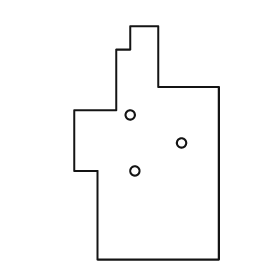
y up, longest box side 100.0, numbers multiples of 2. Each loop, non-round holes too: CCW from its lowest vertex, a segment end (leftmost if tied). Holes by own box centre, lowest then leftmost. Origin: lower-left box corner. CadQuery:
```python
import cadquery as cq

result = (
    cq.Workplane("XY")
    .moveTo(10.0, 0.0)
    .lineTo(62.0, 0.0)
    .lineTo(62.0, 74.0)
    .lineTo(36.0, 74.0)
    .lineTo(36.0, 100.0)
    .lineTo(24.0, 100.0)
    .lineTo(24.0, 90.0)
    .lineTo(18.0, 90.0)
    .lineTo(18.0, 64.0)
    .lineTo(0.0, 64.0)
    .lineTo(0.0, 38.0)
    .lineTo(10.0, 38.0)
    .close()
    .moveTo(26.0, 38.0)
    .circle(2.0)
    .moveTo(46.0, 50.0)
    .circle(2.0)
    .moveTo(24.0, 62.0)
    .circle(2.0)
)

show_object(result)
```